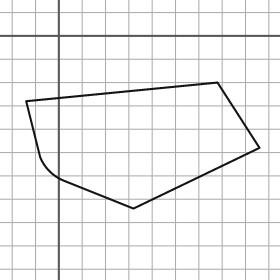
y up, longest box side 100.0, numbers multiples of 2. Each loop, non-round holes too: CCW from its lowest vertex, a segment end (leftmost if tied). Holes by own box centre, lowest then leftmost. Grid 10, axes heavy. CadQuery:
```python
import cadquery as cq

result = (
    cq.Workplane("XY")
    .moveTo(32.0, -74.0)
    .lineTo(86.0, -48.0)
    .lineTo(68.0, -20.0)
    .lineTo(-14.0, -28.0)
    .lineTo(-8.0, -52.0)
    .threePointArc((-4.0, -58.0), (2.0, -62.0))
    .close()
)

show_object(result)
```